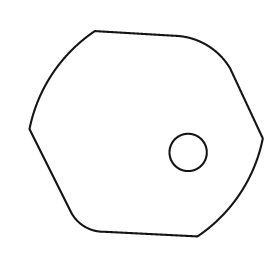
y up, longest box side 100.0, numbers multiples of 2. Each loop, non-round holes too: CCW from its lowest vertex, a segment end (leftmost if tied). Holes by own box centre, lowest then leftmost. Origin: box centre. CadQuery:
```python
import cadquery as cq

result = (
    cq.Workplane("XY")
    .moveTo(22.0, -44.0)
    .threePointArc((40.0, -26.0), (50.0, -2.0))
    .lineTo(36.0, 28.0)
    .threePointArc((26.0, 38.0), (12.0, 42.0))
    .lineTo(-22.0, 44.0)
    .threePointArc((-40.0, 26.0), (-50.0, 2.0))
    .lineTo(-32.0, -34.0)
    .threePointArc((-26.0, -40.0), (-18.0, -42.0))
    .close()
    .moveTo(18.0, -8.0)
    .circle(8.0)
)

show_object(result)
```